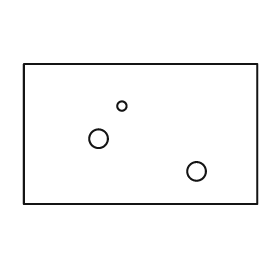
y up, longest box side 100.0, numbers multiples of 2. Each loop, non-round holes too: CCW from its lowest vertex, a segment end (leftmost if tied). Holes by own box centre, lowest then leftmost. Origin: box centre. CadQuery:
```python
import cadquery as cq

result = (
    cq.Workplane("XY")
    .moveTo(-50.0, -30.0)
    .lineTo(50.0, -30.0)
    .lineTo(50.0, 30.0)
    .lineTo(-50.0, 30.0)
    .close()
    .moveTo(24.0, -16.0)
    .circle(4.0)
    .moveTo(-18.0, -2.0)
    .circle(4.0)
    .moveTo(-8.0, 12.0)
    .circle(2.0)
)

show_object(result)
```